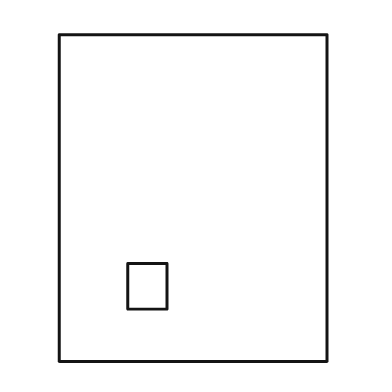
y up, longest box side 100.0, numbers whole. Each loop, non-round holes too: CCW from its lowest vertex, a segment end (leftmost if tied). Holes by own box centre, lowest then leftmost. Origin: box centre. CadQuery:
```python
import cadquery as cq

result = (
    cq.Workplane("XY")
    .moveTo(-41.0, -50.0)
    .lineTo(41.0, -50.0)
    .lineTo(41.0, 50.0)
    .lineTo(-41.0, 50.0)
    .close()
    .moveTo(-20.0, -34.0)
    .lineTo(-8.0, -34.0)
    .lineTo(-8.0, -20.0)
    .lineTo(-20.0, -20.0)
    .close()
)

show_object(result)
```